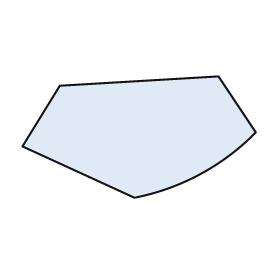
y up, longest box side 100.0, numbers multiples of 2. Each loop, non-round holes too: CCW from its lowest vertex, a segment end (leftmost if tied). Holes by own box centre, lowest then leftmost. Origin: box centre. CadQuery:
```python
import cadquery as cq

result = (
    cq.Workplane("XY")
    .moveTo(-2.0, -26.0)
    .threePointArc((26.0, -16.0), (50.0, 2.0))
    .lineTo(34.0, 26.0)
    .lineTo(-34.0, 22.0)
    .lineTo(-50.0, -4.0)
    .close()
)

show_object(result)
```